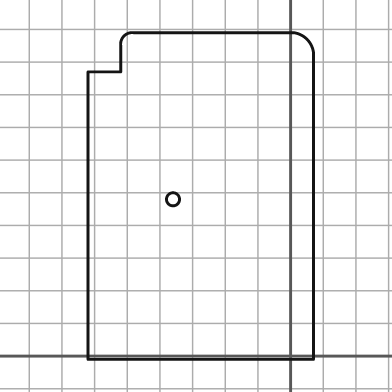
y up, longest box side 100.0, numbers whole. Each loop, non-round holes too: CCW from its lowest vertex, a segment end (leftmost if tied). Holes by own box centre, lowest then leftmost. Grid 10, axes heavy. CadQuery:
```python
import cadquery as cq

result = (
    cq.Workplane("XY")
    .moveTo(-62.0, -1.0)
    .lineTo(7.0, -1.0)
    .lineTo(7.0, 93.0)
    .threePointArc((5.0, 97.0), (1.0, 99.0))
    .lineTo(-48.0, 99.0)
    .threePointArc((-51.0, 98.0), (-52.0, 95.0))
    .lineTo(-52.0, 87.0)
    .lineTo(-62.0, 87.0)
    .close()
    .moveTo(-36.0, 48.0)
    .circle(2.0)
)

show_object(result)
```